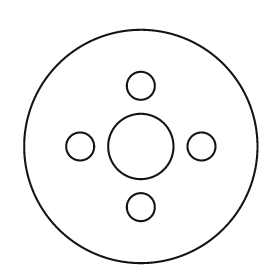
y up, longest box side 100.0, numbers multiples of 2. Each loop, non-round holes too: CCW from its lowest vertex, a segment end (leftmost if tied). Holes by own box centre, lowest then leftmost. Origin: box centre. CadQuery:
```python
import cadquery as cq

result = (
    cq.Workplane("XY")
    .moveTo(0.0, 0.0)
    .circle(50.0)
    .moveTo(0.0, -26.0)
    .circle(6.0)
    .moveTo(-26.0, 0.0)
    .circle(6.0)
    .moveTo(0.0, 0.0)
    .circle(14.0)
    .moveTo(26.0, 0.0)
    .circle(6.0)
    .moveTo(0.0, 26.0)
    .circle(6.0)
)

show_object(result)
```